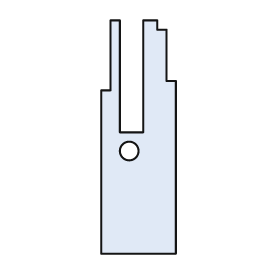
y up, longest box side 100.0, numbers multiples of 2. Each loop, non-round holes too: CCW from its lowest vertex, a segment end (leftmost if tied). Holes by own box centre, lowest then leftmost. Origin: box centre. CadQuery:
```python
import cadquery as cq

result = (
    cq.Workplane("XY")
    .moveTo(-16.0, -50.0)
    .lineTo(16.0, -50.0)
    .lineTo(16.0, 24.0)
    .lineTo(12.0, 24.0)
    .lineTo(12.0, 46.0)
    .lineTo(8.0, 46.0)
    .lineTo(8.0, 50.0)
    .lineTo(2.0, 50.0)
    .lineTo(2.0, 2.0)
    .lineTo(-8.0, 2.0)
    .lineTo(-8.0, 50.0)
    .lineTo(-12.0, 50.0)
    .lineTo(-12.0, 20.0)
    .lineTo(-16.0, 20.0)
    .close()
    .moveTo(-4.0, -6.0)
    .circle(4.0)
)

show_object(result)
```